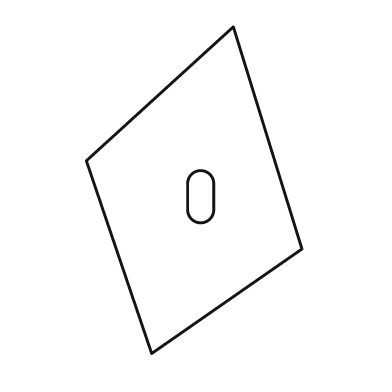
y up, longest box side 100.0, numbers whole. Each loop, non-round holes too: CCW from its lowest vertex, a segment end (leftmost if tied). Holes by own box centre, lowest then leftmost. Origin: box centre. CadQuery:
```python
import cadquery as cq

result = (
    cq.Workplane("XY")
    .moveTo(-13.0, -50.0)
    .lineTo(33.0, -18.0)
    .lineTo(12.0, 50.0)
    .lineTo(-33.0, 9.0)
    .close()
    .moveTo(-2.0, -6.0)
    .threePointArc((2.0, -10.0), (6.0, -6.0))
    .lineTo(6.0, 2.0)
    .threePointArc((2.0, 6.0), (-2.0, 2.0))
    .close()
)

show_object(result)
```